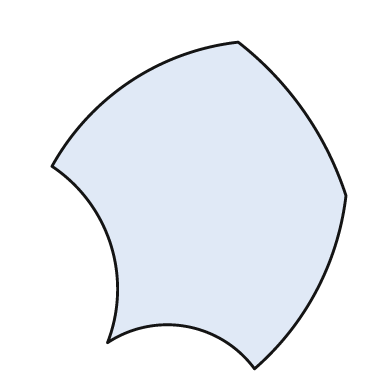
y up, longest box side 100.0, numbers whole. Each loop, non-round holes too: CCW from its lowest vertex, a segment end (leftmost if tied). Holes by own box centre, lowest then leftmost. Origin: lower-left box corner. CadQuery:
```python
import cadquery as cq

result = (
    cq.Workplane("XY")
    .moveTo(62.0, 0.0)
    .threePointArc((81.0, 24.0), (90.0, 53.0))
    .threePointArc((77.0, 79.0), (57.0, 100.0))
    .threePointArc((24.0, 88.0), (0.0, 62.0))
    .threePointArc((18.0, 38.0), (17.0, 8.0))
    .threePointArc((41.0, 13.0), (62.0, 0.0))
    .close()
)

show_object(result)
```